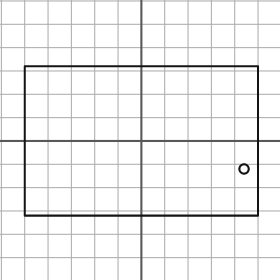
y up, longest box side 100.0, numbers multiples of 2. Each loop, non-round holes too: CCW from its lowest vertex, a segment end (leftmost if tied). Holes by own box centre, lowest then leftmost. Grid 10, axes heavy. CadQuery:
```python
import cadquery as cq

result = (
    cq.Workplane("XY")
    .moveTo(-50.0, -32.0)
    .lineTo(50.0, -32.0)
    .lineTo(50.0, 32.0)
    .lineTo(-50.0, 32.0)
    .close()
    .moveTo(44.0, -12.0)
    .circle(2.0)
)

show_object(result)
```